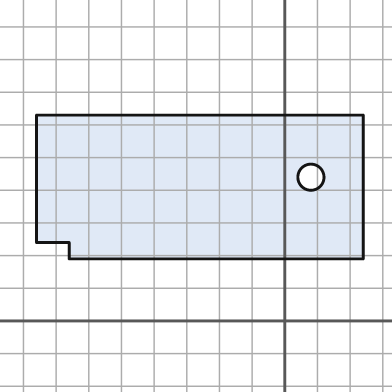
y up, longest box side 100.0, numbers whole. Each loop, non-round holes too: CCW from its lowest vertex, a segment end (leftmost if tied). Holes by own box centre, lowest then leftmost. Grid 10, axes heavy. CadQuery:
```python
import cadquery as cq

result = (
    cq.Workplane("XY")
    .moveTo(-66.0, 19.0)
    .lineTo(24.0, 19.0)
    .lineTo(24.0, 63.0)
    .lineTo(-76.0, 63.0)
    .lineTo(-76.0, 24.0)
    .lineTo(-66.0, 24.0)
    .close()
    .moveTo(8.0, 44.0)
    .circle(4.0)
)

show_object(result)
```